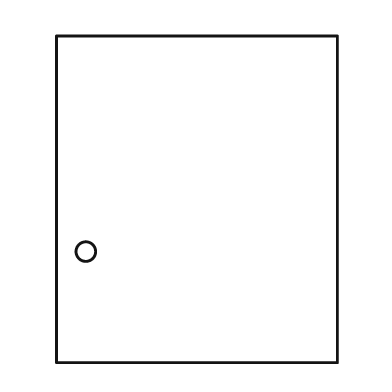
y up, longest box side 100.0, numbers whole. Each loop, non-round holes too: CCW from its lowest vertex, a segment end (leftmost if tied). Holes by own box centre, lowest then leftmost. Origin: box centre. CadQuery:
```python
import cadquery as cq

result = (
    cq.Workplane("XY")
    .moveTo(-43.0, -50.0)
    .lineTo(43.0, -50.0)
    .lineTo(43.0, 50.0)
    .lineTo(-43.0, 50.0)
    .close()
    .moveTo(-34.0, -16.0)
    .circle(3.0)
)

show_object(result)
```